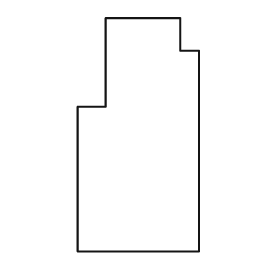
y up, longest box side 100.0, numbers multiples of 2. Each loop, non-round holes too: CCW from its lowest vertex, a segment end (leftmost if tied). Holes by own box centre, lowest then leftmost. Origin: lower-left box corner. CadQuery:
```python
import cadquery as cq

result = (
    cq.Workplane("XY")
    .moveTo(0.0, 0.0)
    .lineTo(52.0, 0.0)
    .lineTo(52.0, 86.0)
    .lineTo(44.0, 86.0)
    .lineTo(44.0, 100.0)
    .lineTo(12.0, 100.0)
    .lineTo(12.0, 62.0)
    .lineTo(0.0, 62.0)
    .close()
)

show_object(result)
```